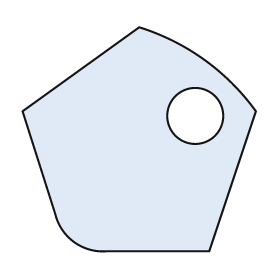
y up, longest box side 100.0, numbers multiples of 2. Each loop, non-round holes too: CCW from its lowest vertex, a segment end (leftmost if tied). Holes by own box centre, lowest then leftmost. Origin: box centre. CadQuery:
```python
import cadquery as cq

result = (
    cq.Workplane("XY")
    .moveTo(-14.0, -48.0)
    .lineTo(30.0, -48.0)
    .lineTo(50.0, 12.0)
    .threePointArc((28.0, 34.0), (0.0, 48.0))
    .lineTo(-50.0, 12.0)
    .lineTo(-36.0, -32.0)
    .threePointArc((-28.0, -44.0), (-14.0, -48.0))
    .close()
    .moveTo(24.0, 10.0)
    .circle(12.0)
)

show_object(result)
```